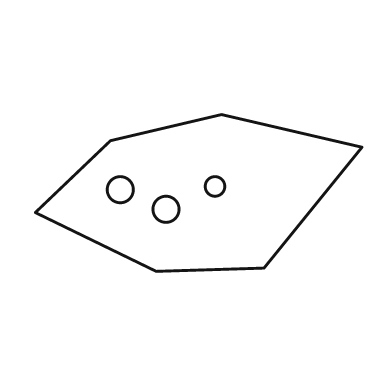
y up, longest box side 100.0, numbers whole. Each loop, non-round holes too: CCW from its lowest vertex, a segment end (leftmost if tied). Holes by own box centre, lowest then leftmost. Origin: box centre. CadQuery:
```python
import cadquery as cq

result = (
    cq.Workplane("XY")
    .moveTo(-13.0, -24.0)
    .lineTo(20.0, -23.0)
    .lineTo(50.0, 14.0)
    .lineTo(7.0, 24.0)
    .lineTo(-27.0, 16.0)
    .lineTo(-50.0, -6.0)
    .close()
    .moveTo(-10.0, -5.0)
    .circle(4.0)
    .moveTo(-24.0, 1.0)
    .circle(4.0)
    .moveTo(5.0, 2.0)
    .circle(3.0)
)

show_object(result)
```